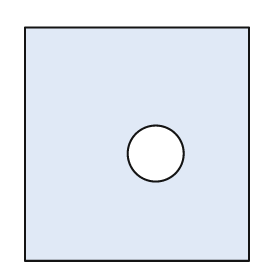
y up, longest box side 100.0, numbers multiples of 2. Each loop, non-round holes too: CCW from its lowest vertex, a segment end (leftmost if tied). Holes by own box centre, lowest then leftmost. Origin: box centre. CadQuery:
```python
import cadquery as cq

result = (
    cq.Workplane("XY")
    .moveTo(-48.0, -50.0)
    .lineTo(48.0, -50.0)
    .lineTo(48.0, 50.0)
    .lineTo(-48.0, 50.0)
    .close()
    .moveTo(8.0, -4.0)
    .circle(12.0)
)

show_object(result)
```